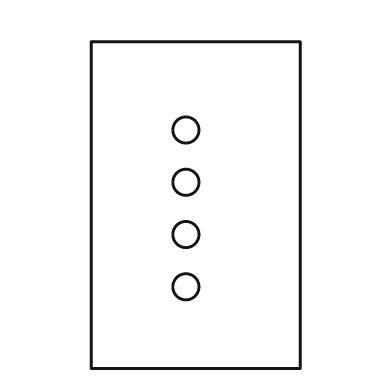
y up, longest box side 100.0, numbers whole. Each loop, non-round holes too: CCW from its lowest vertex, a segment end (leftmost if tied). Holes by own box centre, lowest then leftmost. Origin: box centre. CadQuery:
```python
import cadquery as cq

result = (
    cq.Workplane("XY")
    .moveTo(-32.0, -50.0)
    .lineTo(32.0, -50.0)
    .lineTo(32.0, 50.0)
    .lineTo(-32.0, 50.0)
    .close()
    .moveTo(-3.0, -25.0)
    .circle(4.0)
    .moveTo(-3.0, -9.0)
    .circle(4.0)
    .moveTo(-3.0, 7.0)
    .circle(4.0)
    .moveTo(-3.0, 23.0)
    .circle(4.0)
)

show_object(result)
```